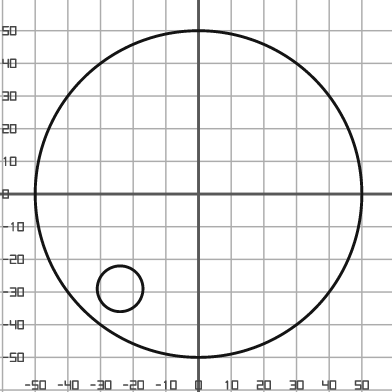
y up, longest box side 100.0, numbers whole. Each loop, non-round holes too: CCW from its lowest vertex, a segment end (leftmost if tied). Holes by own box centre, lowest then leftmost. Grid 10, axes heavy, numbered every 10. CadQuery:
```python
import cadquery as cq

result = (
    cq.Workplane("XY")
    .moveTo(0.0, 0.0)
    .circle(50.0)
    .moveTo(-24.0, -29.0)
    .circle(7.0)
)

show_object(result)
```